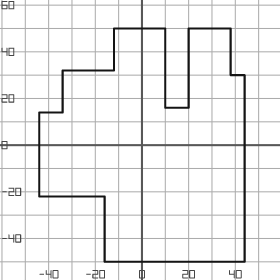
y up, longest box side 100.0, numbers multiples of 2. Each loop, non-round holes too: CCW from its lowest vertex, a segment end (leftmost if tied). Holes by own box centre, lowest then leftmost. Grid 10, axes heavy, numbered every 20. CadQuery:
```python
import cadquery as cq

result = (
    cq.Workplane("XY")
    .moveTo(-16.0, -50.0)
    .lineTo(44.0, -50.0)
    .lineTo(44.0, 30.0)
    .lineTo(38.0, 30.0)
    .lineTo(38.0, 50.0)
    .lineTo(20.0, 50.0)
    .lineTo(20.0, 16.0)
    .lineTo(10.0, 16.0)
    .lineTo(10.0, 50.0)
    .lineTo(-12.0, 50.0)
    .lineTo(-12.0, 32.0)
    .lineTo(-34.0, 32.0)
    .lineTo(-34.0, 14.0)
    .lineTo(-44.0, 14.0)
    .lineTo(-44.0, -22.0)
    .lineTo(-16.0, -22.0)
    .close()
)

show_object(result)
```